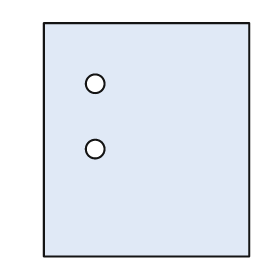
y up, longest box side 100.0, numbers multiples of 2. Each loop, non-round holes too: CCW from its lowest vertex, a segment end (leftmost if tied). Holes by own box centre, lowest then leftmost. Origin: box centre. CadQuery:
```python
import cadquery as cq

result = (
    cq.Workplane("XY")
    .moveTo(-44.0, -50.0)
    .lineTo(44.0, -50.0)
    .lineTo(44.0, 50.0)
    .lineTo(-44.0, 50.0)
    .close()
    .moveTo(-22.0, -4.0)
    .circle(4.0)
    .moveTo(-22.0, 24.0)
    .circle(4.0)
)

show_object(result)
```